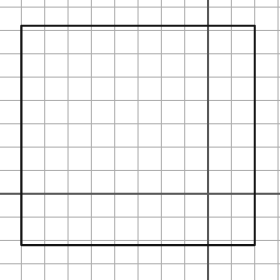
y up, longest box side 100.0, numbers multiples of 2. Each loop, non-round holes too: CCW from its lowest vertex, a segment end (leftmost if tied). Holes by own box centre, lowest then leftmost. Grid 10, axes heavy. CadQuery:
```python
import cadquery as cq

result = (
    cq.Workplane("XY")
    .moveTo(-80.0, -22.0)
    .lineTo(20.0, -22.0)
    .lineTo(20.0, 72.0)
    .lineTo(-80.0, 72.0)
    .close()
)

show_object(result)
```